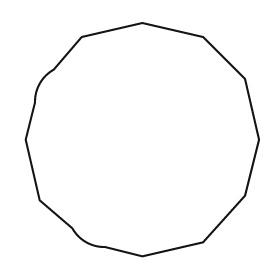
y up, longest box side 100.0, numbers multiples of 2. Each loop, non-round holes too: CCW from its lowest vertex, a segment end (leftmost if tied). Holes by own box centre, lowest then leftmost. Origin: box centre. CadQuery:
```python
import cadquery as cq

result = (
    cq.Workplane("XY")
    .moveTo(0.0, -50.0)
    .lineTo(26.0, -44.0)
    .lineTo(44.0, -24.0)
    .lineTo(50.0, 0.0)
    .lineTo(44.0, 26.0)
    .lineTo(26.0, 44.0)
    .lineTo(0.0, 50.0)
    .lineTo(-26.0, 44.0)
    .lineTo(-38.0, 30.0)
    .threePointArc((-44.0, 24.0), (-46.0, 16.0))
    .lineTo(-50.0, 0.0)
    .lineTo(-44.0, -26.0)
    .lineTo(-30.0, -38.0)
    .threePointArc((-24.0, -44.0), (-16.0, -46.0))
    .close()
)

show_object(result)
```